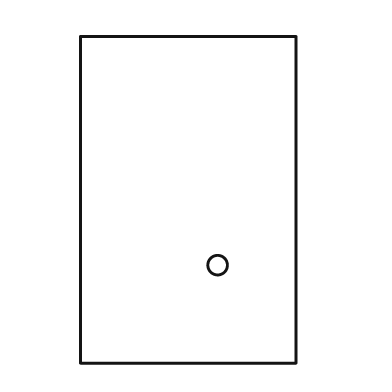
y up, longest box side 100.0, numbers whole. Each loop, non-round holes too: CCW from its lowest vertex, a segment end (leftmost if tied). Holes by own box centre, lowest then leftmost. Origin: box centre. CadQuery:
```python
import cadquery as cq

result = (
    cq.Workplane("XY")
    .moveTo(-33.0, -50.0)
    .lineTo(33.0, -50.0)
    .lineTo(33.0, 50.0)
    .lineTo(-33.0, 50.0)
    .close()
    .moveTo(9.0, -20.0)
    .circle(3.0)
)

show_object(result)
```